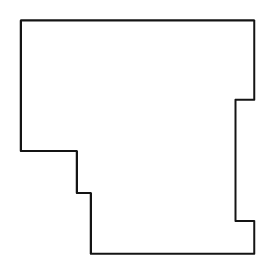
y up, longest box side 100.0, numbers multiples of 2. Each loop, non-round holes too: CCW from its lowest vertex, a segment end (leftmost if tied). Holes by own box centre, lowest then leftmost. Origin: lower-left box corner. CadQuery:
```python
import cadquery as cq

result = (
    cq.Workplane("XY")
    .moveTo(30.0, 0.0)
    .lineTo(100.0, 0.0)
    .lineTo(100.0, 14.0)
    .lineTo(92.0, 14.0)
    .lineTo(92.0, 66.0)
    .lineTo(100.0, 66.0)
    .lineTo(100.0, 100.0)
    .lineTo(0.0, 100.0)
    .lineTo(0.0, 44.0)
    .lineTo(24.0, 44.0)
    .lineTo(24.0, 26.0)
    .lineTo(30.0, 26.0)
    .close()
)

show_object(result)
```